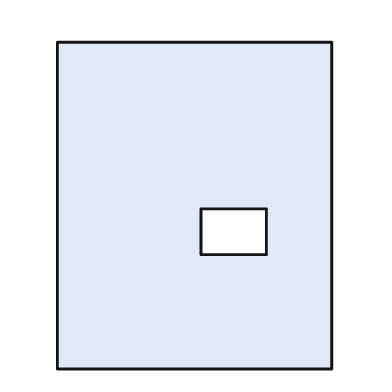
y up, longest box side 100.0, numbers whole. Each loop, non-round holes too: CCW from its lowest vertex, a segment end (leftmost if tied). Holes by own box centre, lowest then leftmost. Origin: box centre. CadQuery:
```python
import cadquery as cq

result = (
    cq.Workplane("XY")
    .moveTo(-42.0, -50.0)
    .lineTo(42.0, -50.0)
    .lineTo(42.0, 50.0)
    .lineTo(-42.0, 50.0)
    .close()
    .moveTo(2.0, -15.0)
    .lineTo(22.0, -15.0)
    .lineTo(22.0, -1.0)
    .lineTo(2.0, -1.0)
    .close()
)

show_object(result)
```